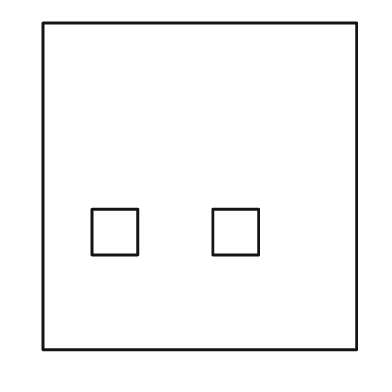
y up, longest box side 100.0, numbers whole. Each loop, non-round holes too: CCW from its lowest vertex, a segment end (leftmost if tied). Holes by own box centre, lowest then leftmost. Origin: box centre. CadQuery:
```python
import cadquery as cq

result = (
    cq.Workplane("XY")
    .moveTo(-48.0, -50.0)
    .lineTo(48.0, -50.0)
    .lineTo(48.0, 50.0)
    .lineTo(-48.0, 50.0)
    .close()
    .moveTo(-33.0, -21.0)
    .lineTo(-19.0, -21.0)
    .lineTo(-19.0, -7.0)
    .lineTo(-33.0, -7.0)
    .close()
    .moveTo(4.0, -21.0)
    .lineTo(18.0, -21.0)
    .lineTo(18.0, -7.0)
    .lineTo(4.0, -7.0)
    .close()
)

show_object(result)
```